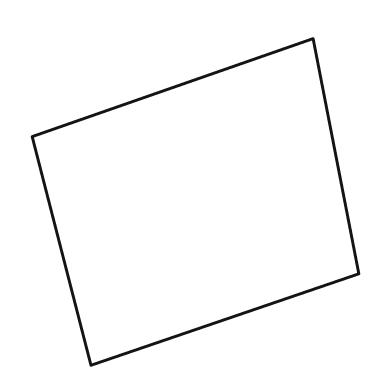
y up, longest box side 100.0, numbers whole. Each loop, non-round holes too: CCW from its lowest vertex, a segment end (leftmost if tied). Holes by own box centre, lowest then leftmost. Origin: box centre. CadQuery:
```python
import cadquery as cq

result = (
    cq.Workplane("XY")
    .moveTo(-32.0, -50.0)
    .lineTo(50.0, -22.0)
    .lineTo(36.0, 50.0)
    .lineTo(-50.0, 20.0)
    .close()
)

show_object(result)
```